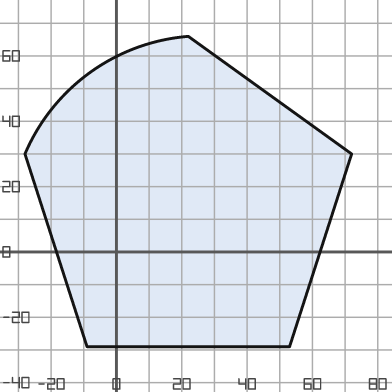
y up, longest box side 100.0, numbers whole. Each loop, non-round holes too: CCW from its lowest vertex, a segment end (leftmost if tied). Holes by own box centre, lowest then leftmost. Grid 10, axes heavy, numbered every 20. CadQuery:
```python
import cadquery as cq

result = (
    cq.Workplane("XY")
    .moveTo(-9.0, -29.0)
    .lineTo(53.0, -29.0)
    .lineTo(72.0, 30.0)
    .lineTo(22.0, 66.0)
    .threePointArc((-8.0, 55.0), (-28.0, 30.0))
    .close()
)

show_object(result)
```